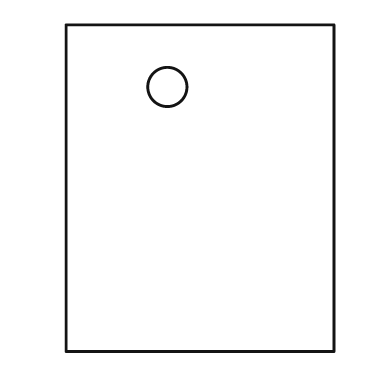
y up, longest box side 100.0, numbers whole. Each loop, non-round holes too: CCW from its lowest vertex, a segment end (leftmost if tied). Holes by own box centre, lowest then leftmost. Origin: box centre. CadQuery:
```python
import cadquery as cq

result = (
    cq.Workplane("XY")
    .moveTo(-41.0, -50.0)
    .lineTo(41.0, -50.0)
    .lineTo(41.0, 50.0)
    .lineTo(-41.0, 50.0)
    .close()
    .moveTo(-10.0, 31.0)
    .circle(6.0)
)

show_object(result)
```